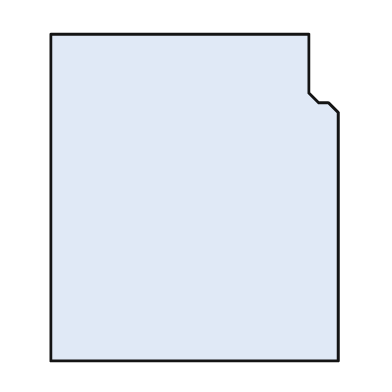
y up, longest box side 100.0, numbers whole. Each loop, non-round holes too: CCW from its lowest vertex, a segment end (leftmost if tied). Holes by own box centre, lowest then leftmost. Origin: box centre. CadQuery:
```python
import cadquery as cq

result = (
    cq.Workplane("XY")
    .moveTo(-44.0, -50.0)
    .lineTo(44.0, -50.0)
    .lineTo(44.0, 26.0)
    .lineTo(41.0, 29.0)
    .lineTo(38.0, 29.0)
    .lineTo(35.0, 32.0)
    .lineTo(35.0, 50.0)
    .lineTo(-44.0, 50.0)
    .close()
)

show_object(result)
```